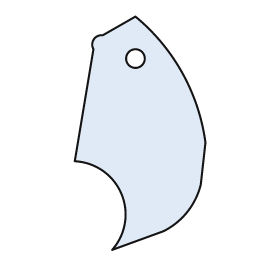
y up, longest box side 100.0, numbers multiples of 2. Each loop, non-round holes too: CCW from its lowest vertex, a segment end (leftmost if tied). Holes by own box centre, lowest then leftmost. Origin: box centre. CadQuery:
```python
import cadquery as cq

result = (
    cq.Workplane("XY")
    .moveTo(-12.0, -50.0)
    .lineTo(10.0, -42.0)
    .threePointArc((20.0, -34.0), (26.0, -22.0))
    .lineTo(28.0, -4.0)
    .threePointArc((18.0, 26.0), (-2.0, 50.0))
    .lineTo(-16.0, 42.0)
    .threePointArc((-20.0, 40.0), (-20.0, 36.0))
    .lineTo(-28.0, -12.0)
    .threePointArc((-8.0, -26.0), (-12.0, -50.0))
    .close()
    .moveTo(-2.0, 32.0)
    .circle(4.0)
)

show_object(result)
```